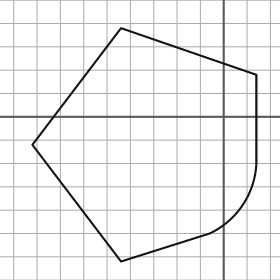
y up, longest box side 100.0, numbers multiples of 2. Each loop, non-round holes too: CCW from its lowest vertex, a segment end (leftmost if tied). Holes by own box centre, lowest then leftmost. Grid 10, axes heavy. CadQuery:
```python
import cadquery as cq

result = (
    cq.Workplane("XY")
    .moveTo(-44.0, -62.0)
    .lineTo(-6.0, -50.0)
    .threePointArc((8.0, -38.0), (14.0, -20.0))
    .lineTo(14.0, 18.0)
    .lineTo(-44.0, 38.0)
    .lineTo(-82.0, -12.0)
    .close()
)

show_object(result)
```